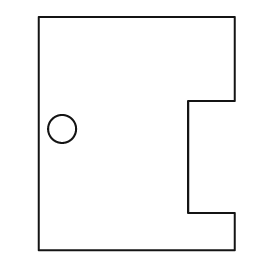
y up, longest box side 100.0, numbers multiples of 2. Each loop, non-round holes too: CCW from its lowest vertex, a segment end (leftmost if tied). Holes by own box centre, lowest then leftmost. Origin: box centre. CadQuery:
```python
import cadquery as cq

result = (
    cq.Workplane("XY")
    .moveTo(-42.0, -50.0)
    .lineTo(42.0, -50.0)
    .lineTo(42.0, -34.0)
    .lineTo(22.0, -34.0)
    .lineTo(22.0, 14.0)
    .lineTo(42.0, 14.0)
    .lineTo(42.0, 50.0)
    .lineTo(-42.0, 50.0)
    .close()
    .moveTo(-32.0, 2.0)
    .circle(6.0)
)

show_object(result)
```